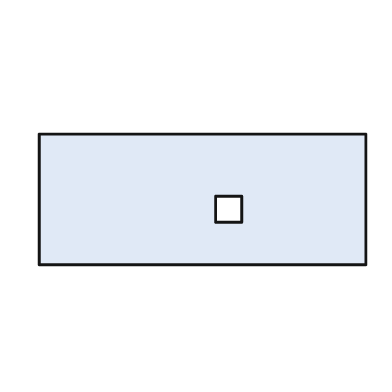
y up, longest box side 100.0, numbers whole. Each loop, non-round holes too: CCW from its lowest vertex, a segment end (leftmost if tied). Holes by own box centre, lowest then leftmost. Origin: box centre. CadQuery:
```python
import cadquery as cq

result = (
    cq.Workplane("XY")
    .moveTo(-50.0, -20.0)
    .lineTo(50.0, -20.0)
    .lineTo(50.0, 20.0)
    .lineTo(-50.0, 20.0)
    .close()
    .moveTo(4.0, -7.0)
    .lineTo(12.0, -7.0)
    .lineTo(12.0, 1.0)
    .lineTo(4.0, 1.0)
    .close()
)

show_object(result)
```